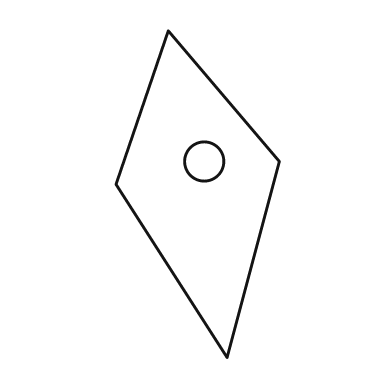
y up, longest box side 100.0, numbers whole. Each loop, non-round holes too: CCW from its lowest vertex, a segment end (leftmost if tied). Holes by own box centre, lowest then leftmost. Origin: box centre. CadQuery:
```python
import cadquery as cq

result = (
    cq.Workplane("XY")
    .moveTo(9.0, -50.0)
    .lineTo(25.0, 10.0)
    .lineTo(-9.0, 50.0)
    .lineTo(-25.0, 3.0)
    .close()
    .moveTo(2.0, 10.0)
    .circle(6.0)
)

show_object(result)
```